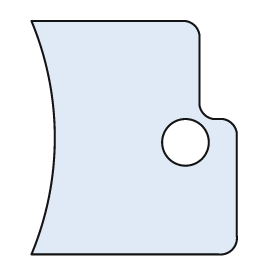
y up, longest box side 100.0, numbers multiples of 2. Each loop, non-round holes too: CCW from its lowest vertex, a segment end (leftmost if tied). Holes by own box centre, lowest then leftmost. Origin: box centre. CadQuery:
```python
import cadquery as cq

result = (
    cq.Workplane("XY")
    .moveTo(-44.0, -50.0)
    .lineTo(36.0, -50.0)
    .threePointArc((42.0, -48.0), (44.0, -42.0))
    .lineTo(44.0, 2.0)
    .threePointArc((42.0, 6.0), (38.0, 8.0))
    .lineTo(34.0, 8.0)
    .threePointArc((30.0, 10.0), (28.0, 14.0))
    .lineTo(28.0, 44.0)
    .threePointArc((26.0, 48.0), (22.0, 50.0))
    .lineTo(-44.0, 50.0)
    .threePointArc((-34.0, 0.0), (-44.0, -50.0))
    .close()
    .moveTo(22.0, -2.0)
    .circle(10.0)
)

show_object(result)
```